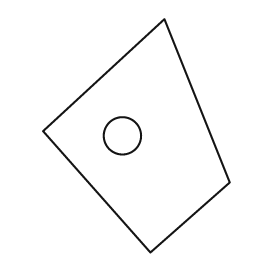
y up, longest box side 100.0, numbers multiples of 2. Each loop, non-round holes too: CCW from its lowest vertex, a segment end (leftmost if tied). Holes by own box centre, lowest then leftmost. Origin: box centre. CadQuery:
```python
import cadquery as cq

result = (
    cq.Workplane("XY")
    .moveTo(6.0, -50.0)
    .lineTo(40.0, -20.0)
    .lineTo(12.0, 50.0)
    .lineTo(-40.0, 2.0)
    .close()
    .moveTo(-6.0, 0.0)
    .circle(8.0)
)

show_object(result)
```